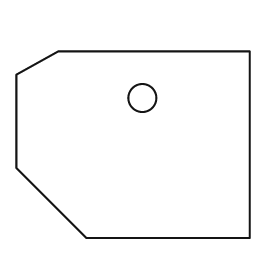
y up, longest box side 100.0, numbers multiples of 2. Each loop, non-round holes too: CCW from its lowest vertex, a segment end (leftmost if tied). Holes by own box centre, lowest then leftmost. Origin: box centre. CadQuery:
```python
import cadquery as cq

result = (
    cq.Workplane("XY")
    .moveTo(-20.0, -40.0)
    .lineTo(50.0, -40.0)
    .lineTo(50.0, 40.0)
    .lineTo(-32.0, 40.0)
    .lineTo(-50.0, 30.0)
    .lineTo(-50.0, -10.0)
    .close()
    .moveTo(4.0, 20.0)
    .circle(6.0)
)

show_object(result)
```